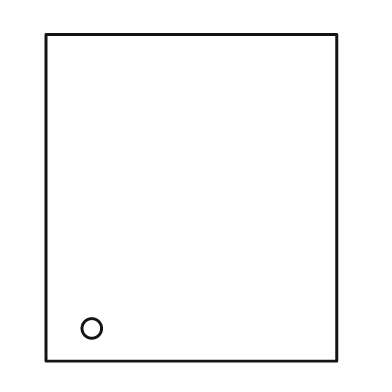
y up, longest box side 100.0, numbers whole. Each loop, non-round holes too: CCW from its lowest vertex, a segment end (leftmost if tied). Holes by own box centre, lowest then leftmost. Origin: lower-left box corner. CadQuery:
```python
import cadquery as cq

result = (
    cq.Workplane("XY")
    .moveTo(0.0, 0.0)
    .lineTo(89.0, 0.0)
    .lineTo(89.0, 100.0)
    .lineTo(0.0, 100.0)
    .close()
    .moveTo(14.0, 10.0)
    .circle(3.0)
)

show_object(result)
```